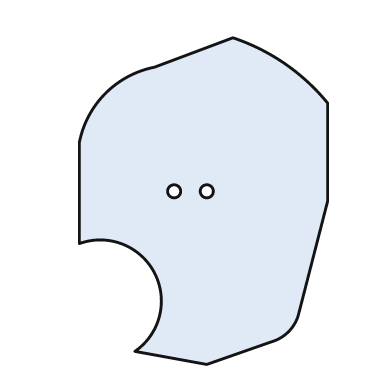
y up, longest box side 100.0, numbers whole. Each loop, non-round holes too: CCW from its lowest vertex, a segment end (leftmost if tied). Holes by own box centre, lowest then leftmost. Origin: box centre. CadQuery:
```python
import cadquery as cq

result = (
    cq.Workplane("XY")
    .moveTo(1.0, -50.0)
    .lineTo(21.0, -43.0)
    .threePointArc((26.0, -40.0), (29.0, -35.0))
    .lineTo(38.0, 0.0)
    .lineTo(38.0, 30.0)
    .threePointArc((25.0, 42.0), (9.0, 50.0))
    .lineTo(-15.0, 41.0)
    .threePointArc((-30.0, 33.0), (-38.0, 18.0))
    .lineTo(-38.0, -13.0)
    .threePointArc((-15.0, -22.0), (-21.0, -46.0))
    .close()
    .moveTo(-9.0, 3.0)
    .circle(2.0)
    .moveTo(1.0, 3.0)
    .circle(2.0)
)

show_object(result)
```